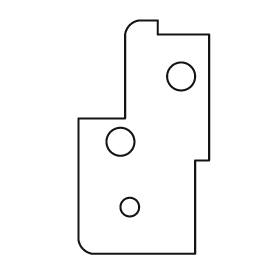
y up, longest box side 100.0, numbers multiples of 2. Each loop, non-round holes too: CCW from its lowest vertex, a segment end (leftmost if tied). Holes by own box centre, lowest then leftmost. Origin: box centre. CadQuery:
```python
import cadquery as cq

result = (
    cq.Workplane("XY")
    .moveTo(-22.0, -50.0)
    .lineTo(22.0, -50.0)
    .lineTo(22.0, -10.0)
    .lineTo(28.0, -10.0)
    .lineTo(28.0, 44.0)
    .lineTo(6.0, 44.0)
    .lineTo(6.0, 50.0)
    .lineTo(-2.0, 50.0)
    .threePointArc((-6.0, 48.0), (-8.0, 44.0))
    .lineTo(-8.0, 8.0)
    .lineTo(-28.0, 8.0)
    .lineTo(-28.0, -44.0)
    .threePointArc((-26.0, -48.0), (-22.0, -50.0))
    .close()
    .moveTo(-6.0, -30.0)
    .circle(4.0)
    .moveTo(-10.0, -2.0)
    .circle(6.0)
    .moveTo(16.0, 26.0)
    .circle(6.0)
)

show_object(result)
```